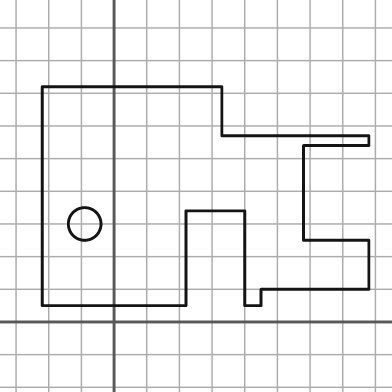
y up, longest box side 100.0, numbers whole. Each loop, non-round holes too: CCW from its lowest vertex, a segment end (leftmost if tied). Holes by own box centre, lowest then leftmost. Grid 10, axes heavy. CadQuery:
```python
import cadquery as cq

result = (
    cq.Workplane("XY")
    .moveTo(-22.0, 5.0)
    .lineTo(22.0, 5.0)
    .lineTo(22.0, 34.0)
    .lineTo(40.0, 34.0)
    .lineTo(40.0, 5.0)
    .lineTo(45.0, 5.0)
    .lineTo(45.0, 10.0)
    .lineTo(78.0, 10.0)
    .lineTo(78.0, 25.0)
    .lineTo(58.0, 25.0)
    .lineTo(58.0, 54.0)
    .lineTo(78.0, 54.0)
    .lineTo(78.0, 57.0)
    .lineTo(33.0, 57.0)
    .lineTo(33.0, 72.0)
    .lineTo(-22.0, 72.0)
    .close()
    .moveTo(-9.0, 30.0)
    .circle(5.0)
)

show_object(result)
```